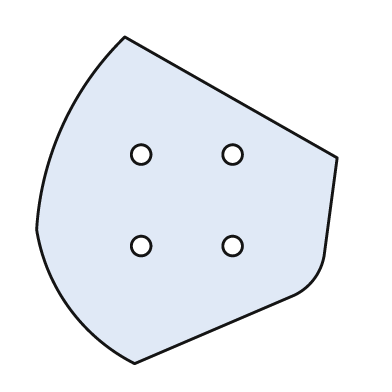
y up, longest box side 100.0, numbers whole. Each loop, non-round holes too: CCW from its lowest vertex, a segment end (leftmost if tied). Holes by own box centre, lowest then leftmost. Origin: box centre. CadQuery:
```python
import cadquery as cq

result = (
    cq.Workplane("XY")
    .moveTo(-16.0, -50.0)
    .lineTo(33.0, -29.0)
    .threePointArc((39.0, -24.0), (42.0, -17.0))
    .lineTo(46.0, 13.0)
    .lineTo(-19.0, 50.0)
    .threePointArc((-38.0, 23.0), (-46.0, -9.0))
    .threePointArc((-36.0, -33.0), (-16.0, -50.0))
    .close()
    .moveTo(-14.0, -14.0)
    .circle(3.0)
    .moveTo(14.0, -14.0)
    .circle(3.0)
    .moveTo(-14.0, 14.0)
    .circle(3.0)
    .moveTo(14.0, 14.0)
    .circle(3.0)
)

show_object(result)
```